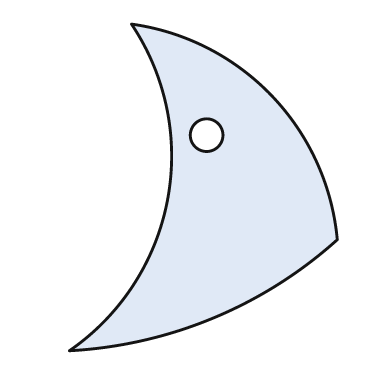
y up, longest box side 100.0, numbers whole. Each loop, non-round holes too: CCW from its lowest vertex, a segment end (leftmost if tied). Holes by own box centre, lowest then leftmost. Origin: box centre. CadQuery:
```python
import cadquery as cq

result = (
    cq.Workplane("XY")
    .moveTo(-41.0, -50.0)
    .threePointArc((3.0, -40.0), (41.0, -16.0))
    .threePointArc((21.0, 28.0), (-22.0, 50.0))
    .threePointArc((-11.0, -4.0), (-41.0, -50.0))
    .close()
    .moveTo(1.0, 16.0)
    .circle(5.0)
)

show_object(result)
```